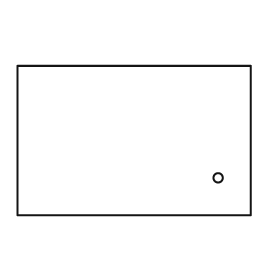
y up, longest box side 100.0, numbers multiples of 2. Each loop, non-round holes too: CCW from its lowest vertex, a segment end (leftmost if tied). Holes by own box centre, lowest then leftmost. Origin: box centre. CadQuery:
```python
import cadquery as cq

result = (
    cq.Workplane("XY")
    .moveTo(-50.0, -32.0)
    .lineTo(50.0, -32.0)
    .lineTo(50.0, 32.0)
    .lineTo(-50.0, 32.0)
    .close()
    .moveTo(36.0, -16.0)
    .circle(2.0)
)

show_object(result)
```